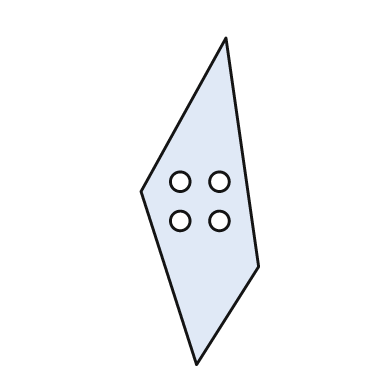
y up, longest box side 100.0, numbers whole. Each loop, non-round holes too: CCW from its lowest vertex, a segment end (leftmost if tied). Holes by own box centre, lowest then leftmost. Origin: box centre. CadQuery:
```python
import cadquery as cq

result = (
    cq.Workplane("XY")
    .moveTo(-1.0, -50.0)
    .lineTo(18.0, -20.0)
    .lineTo(8.0, 50.0)
    .lineTo(-18.0, 3.0)
    .close()
    .moveTo(-6.0, -6.0)
    .circle(3.0)
    .moveTo(6.0, -6.0)
    .circle(3.0)
    .moveTo(-6.0, 6.0)
    .circle(3.0)
    .moveTo(6.0, 6.0)
    .circle(3.0)
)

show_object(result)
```